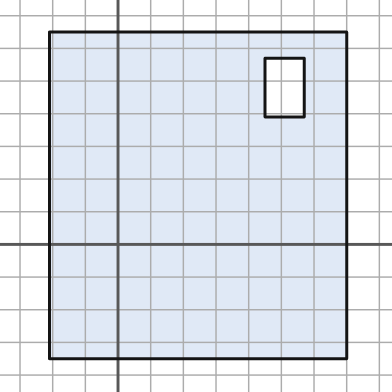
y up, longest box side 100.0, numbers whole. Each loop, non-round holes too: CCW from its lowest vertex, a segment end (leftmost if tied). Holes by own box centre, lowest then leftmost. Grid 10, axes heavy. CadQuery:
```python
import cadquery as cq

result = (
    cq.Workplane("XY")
    .moveTo(-21.0, -35.0)
    .lineTo(70.0, -35.0)
    .lineTo(70.0, 65.0)
    .lineTo(-21.0, 65.0)
    .close()
    .moveTo(45.0, 39.0)
    .lineTo(57.0, 39.0)
    .lineTo(57.0, 57.0)
    .lineTo(45.0, 57.0)
    .close()
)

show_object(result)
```